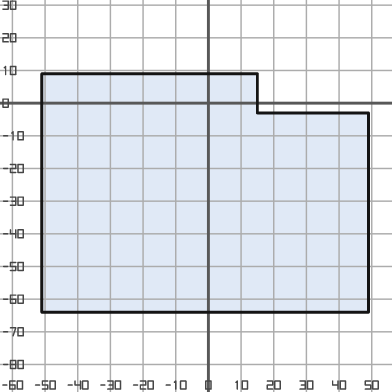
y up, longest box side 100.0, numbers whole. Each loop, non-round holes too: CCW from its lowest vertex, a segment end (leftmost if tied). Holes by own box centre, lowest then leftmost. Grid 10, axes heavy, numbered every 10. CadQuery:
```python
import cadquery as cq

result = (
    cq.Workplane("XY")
    .moveTo(-51.0, -64.0)
    .lineTo(49.0, -64.0)
    .lineTo(49.0, -3.0)
    .lineTo(15.0, -3.0)
    .lineTo(15.0, 9.0)
    .lineTo(-51.0, 9.0)
    .close()
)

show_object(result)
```